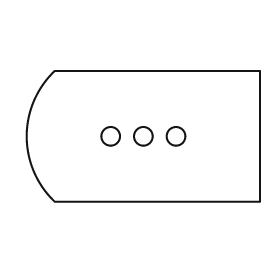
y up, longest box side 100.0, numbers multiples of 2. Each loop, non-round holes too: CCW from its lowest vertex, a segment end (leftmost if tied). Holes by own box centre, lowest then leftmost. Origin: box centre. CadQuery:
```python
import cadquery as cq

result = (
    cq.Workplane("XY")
    .moveTo(-38.0, -28.0)
    .lineTo(50.0, -28.0)
    .lineTo(50.0, 28.0)
    .lineTo(-38.0, 28.0)
    .threePointArc((-50.0, 0.0), (-38.0, -28.0))
    .close()
    .moveTo(-14.0, 0.0)
    .circle(4.0)
    .moveTo(0.0, 0.0)
    .circle(4.0)
    .moveTo(14.0, 0.0)
    .circle(4.0)
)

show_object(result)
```